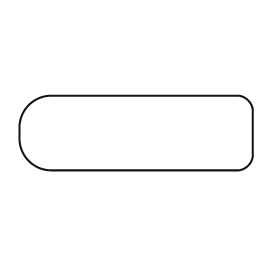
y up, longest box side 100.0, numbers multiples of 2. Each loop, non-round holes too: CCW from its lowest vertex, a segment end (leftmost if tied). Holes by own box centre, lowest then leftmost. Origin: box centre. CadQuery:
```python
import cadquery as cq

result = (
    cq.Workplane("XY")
    .moveTo(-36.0, -16.0)
    .lineTo(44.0, -16.0)
    .threePointArc((48.0, -14.0), (50.0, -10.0))
    .lineTo(50.0, 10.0)
    .threePointArc((48.0, 14.0), (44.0, 16.0))
    .lineTo(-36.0, 16.0)
    .threePointArc((-46.0, 12.0), (-50.0, 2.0))
    .lineTo(-50.0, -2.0)
    .threePointArc((-46.0, -12.0), (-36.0, -16.0))
    .close()
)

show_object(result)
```